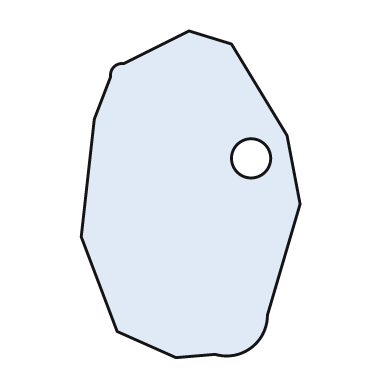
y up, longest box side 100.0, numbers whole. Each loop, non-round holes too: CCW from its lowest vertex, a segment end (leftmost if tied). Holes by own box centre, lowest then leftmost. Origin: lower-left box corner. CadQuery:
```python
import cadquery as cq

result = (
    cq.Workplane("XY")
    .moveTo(29.0, 0.0)
    .lineTo(41.0, 1.0)
    .threePointArc((52.0, 3.0), (57.0, 13.0))
    .lineTo(67.0, 47.0)
    .lineTo(63.0, 68.0)
    .lineTo(46.0, 96.0)
    .lineTo(33.0, 100.0)
    .lineTo(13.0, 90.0)
    .threePointArc((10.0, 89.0), (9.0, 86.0))
    .lineTo(4.0, 73.0)
    .lineTo(0.0, 37.0)
    .lineTo(11.0, 8.0)
    .close()
    .moveTo(52.0, 61.0)
    .circle(6.0)
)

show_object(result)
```